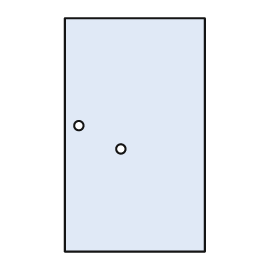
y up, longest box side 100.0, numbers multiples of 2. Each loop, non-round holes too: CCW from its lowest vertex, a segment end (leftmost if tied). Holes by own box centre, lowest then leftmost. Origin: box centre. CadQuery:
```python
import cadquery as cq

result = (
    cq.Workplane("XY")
    .moveTo(-30.0, -50.0)
    .lineTo(30.0, -50.0)
    .lineTo(30.0, 50.0)
    .lineTo(-30.0, 50.0)
    .close()
    .moveTo(-6.0, -6.0)
    .circle(2.0)
    .moveTo(-24.0, 4.0)
    .circle(2.0)
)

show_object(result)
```